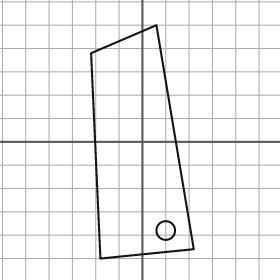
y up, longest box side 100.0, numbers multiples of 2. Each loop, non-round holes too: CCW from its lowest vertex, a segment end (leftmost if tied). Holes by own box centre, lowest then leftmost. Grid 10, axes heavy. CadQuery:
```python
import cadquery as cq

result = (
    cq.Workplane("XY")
    .moveTo(-18.0, -50.0)
    .lineTo(22.0, -46.0)
    .lineTo(6.0, 50.0)
    .lineTo(-22.0, 38.0)
    .close()
    .moveTo(10.0, -38.0)
    .circle(4.0)
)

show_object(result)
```